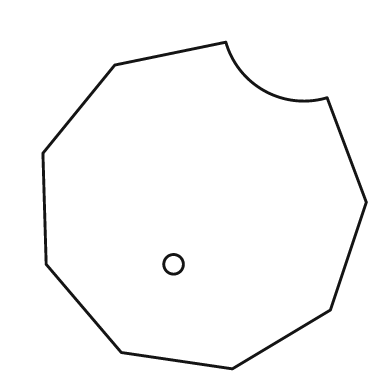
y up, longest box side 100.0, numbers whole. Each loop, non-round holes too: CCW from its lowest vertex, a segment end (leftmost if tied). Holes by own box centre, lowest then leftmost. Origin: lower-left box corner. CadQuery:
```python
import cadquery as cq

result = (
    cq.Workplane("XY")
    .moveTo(58.0, 0.0)
    .lineTo(88.0, 18.0)
    .lineTo(99.0, 51.0)
    .lineTo(87.0, 83.0)
    .threePointArc((68.0, 85.0), (56.0, 100.0))
    .lineTo(22.0, 93.0)
    .lineTo(0.0, 66.0)
    .lineTo(1.0, 32.0)
    .lineTo(24.0, 5.0)
    .close()
    .moveTo(40.0, 32.0)
    .circle(3.0)
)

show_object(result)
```